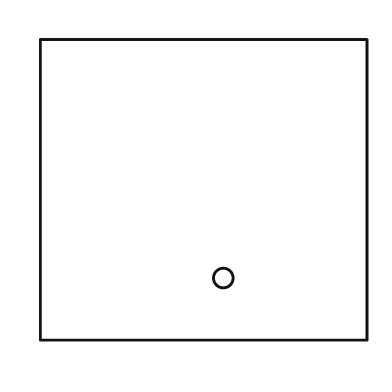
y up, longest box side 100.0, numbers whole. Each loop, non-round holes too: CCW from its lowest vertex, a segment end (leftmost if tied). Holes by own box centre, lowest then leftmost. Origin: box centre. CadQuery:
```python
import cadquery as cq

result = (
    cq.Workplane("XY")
    .moveTo(-50.0, -46.0)
    .lineTo(50.0, -46.0)
    .lineTo(50.0, 46.0)
    .lineTo(-50.0, 46.0)
    .close()
    .moveTo(6.0, -27.0)
    .circle(3.0)
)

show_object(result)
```